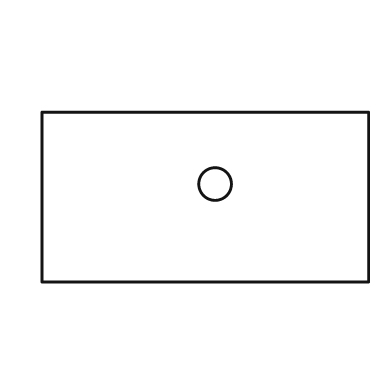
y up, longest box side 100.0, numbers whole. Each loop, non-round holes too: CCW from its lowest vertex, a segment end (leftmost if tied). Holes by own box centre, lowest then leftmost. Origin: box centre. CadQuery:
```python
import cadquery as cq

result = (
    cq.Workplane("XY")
    .moveTo(-50.0, -26.0)
    .lineTo(50.0, -26.0)
    .lineTo(50.0, 26.0)
    .lineTo(-50.0, 26.0)
    .close()
    .moveTo(3.0, 4.0)
    .circle(5.0)
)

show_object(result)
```